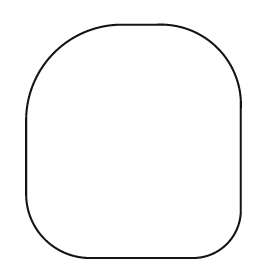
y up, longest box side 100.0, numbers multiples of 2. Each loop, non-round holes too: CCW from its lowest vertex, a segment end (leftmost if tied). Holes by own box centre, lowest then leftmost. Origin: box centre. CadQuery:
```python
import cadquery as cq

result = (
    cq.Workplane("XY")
    .moveTo(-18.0, -50.0)
    .lineTo(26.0, -50.0)
    .threePointArc((40.0, -44.0), (46.0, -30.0))
    .lineTo(46.0, 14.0)
    .threePointArc((36.0, 40.0), (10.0, 50.0))
    .lineTo(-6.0, 50.0)
    .threePointArc((-34.0, 38.0), (-46.0, 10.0))
    .lineTo(-46.0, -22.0)
    .threePointArc((-38.0, -42.0), (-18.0, -50.0))
    .close()
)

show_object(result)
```